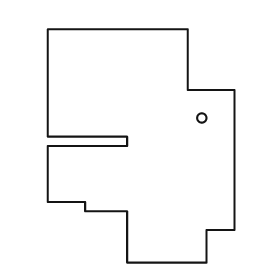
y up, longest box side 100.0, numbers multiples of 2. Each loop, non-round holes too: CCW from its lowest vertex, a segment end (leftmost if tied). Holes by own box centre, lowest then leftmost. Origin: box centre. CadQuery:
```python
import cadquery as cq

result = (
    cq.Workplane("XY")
    .moveTo(-6.0, -50.0)
    .lineTo(28.0, -50.0)
    .lineTo(28.0, -36.0)
    .lineTo(40.0, -36.0)
    .lineTo(40.0, 24.0)
    .lineTo(20.0, 24.0)
    .lineTo(20.0, 50.0)
    .lineTo(-40.0, 50.0)
    .lineTo(-40.0, 4.0)
    .lineTo(-6.0, 4.0)
    .lineTo(-6.0, 0.0)
    .lineTo(-40.0, 0.0)
    .lineTo(-40.0, -24.0)
    .lineTo(-24.0, -24.0)
    .lineTo(-24.0, -28.0)
    .lineTo(-6.0, -28.0)
    .close()
    .moveTo(26.0, 12.0)
    .circle(2.0)
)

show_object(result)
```